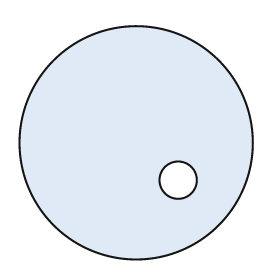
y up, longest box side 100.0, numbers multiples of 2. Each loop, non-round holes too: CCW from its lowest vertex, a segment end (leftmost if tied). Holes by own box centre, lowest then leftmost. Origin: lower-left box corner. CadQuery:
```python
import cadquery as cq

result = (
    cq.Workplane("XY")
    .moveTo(50.0, 50.0)
    .circle(50.0)
    .moveTo(68.0, 34.0)
    .circle(8.0)
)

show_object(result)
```